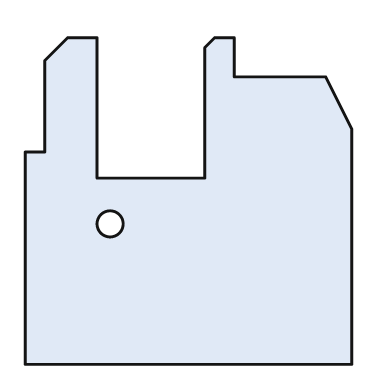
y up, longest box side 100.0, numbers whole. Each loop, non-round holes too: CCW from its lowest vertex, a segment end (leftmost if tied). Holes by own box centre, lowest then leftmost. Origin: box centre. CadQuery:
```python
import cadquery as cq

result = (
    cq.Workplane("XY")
    .moveTo(-50.0, -50.0)
    .lineTo(50.0, -50.0)
    .lineTo(50.0, 22.0)
    .lineTo(42.0, 38.0)
    .lineTo(14.0, 38.0)
    .lineTo(14.0, 50.0)
    .lineTo(8.0, 50.0)
    .lineTo(5.0, 47.0)
    .lineTo(5.0, 7.0)
    .lineTo(-28.0, 7.0)
    .lineTo(-28.0, 50.0)
    .lineTo(-37.0, 50.0)
    .lineTo(-44.0, 43.0)
    .lineTo(-44.0, 15.0)
    .lineTo(-50.0, 15.0)
    .close()
    .moveTo(-24.0, -7.0)
    .circle(4.0)
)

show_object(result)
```